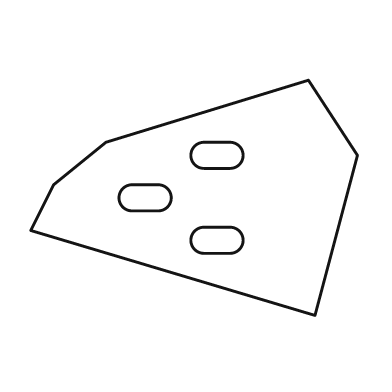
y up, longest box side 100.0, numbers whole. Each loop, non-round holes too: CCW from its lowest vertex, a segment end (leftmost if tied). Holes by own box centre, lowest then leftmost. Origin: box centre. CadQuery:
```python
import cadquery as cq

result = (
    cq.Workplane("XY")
    .moveTo(37.0, -36.0)
    .lineTo(50.0, 13.0)
    .lineTo(35.0, 36.0)
    .lineTo(-27.0, 17.0)
    .lineTo(-43.0, 4.0)
    .lineTo(-50.0, -10.0)
    .close()
    .moveTo(3.0, -17.0)
    .lineTo(11.0, -17.0)
    .threePointArc((15.0, -13.0), (11.0, -9.0))
    .lineTo(3.0, -9.0)
    .threePointArc((-1.0, -13.0), (3.0, -17.0))
    .close()
    .moveTo(-19.0, -4.0)
    .lineTo(-11.0, -4.0)
    .threePointArc((-7.0, 0.0), (-11.0, 4.0))
    .lineTo(-19.0, 4.0)
    .threePointArc((-23.0, 0.0), (-19.0, -4.0))
    .close()
    .moveTo(3.0, 9.0)
    .lineTo(11.0, 9.0)
    .threePointArc((15.0, 13.0), (11.0, 17.0))
    .lineTo(3.0, 17.0)
    .threePointArc((-1.0, 13.0), (3.0, 9.0))
    .close()
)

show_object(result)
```